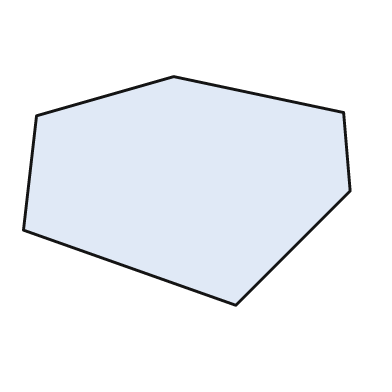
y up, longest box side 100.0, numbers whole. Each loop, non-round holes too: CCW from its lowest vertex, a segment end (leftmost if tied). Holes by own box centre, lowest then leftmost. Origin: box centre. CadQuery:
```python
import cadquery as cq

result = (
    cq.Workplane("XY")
    .moveTo(15.0, -35.0)
    .lineTo(50.0, 0.0)
    .lineTo(48.0, 24.0)
    .lineTo(-4.0, 35.0)
    .lineTo(-46.0, 23.0)
    .lineTo(-50.0, -12.0)
    .close()
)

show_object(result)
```